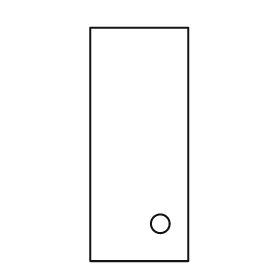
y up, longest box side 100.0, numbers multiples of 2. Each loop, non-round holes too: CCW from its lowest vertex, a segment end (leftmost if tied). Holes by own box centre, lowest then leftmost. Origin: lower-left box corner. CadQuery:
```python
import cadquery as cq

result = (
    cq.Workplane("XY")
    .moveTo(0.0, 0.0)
    .lineTo(42.0, 0.0)
    .lineTo(42.0, 100.0)
    .lineTo(0.0, 100.0)
    .close()
    .moveTo(30.0, 16.0)
    .circle(4.0)
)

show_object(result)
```